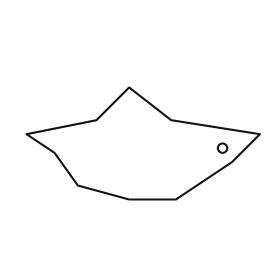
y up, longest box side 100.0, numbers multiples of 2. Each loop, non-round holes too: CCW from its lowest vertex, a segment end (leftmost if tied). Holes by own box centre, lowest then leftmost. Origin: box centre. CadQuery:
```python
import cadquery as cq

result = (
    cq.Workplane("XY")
    .moveTo(-6.0, -24.0)
    .lineTo(14.0, -24.0)
    .lineTo(38.0, -8.0)
    .lineTo(50.0, 4.0)
    .lineTo(12.0, 10.0)
    .lineTo(-6.0, 24.0)
    .lineTo(-20.0, 10.0)
    .lineTo(-50.0, 4.0)
    .lineTo(-38.0, -4.0)
    .lineTo(-28.0, -18.0)
    .close()
    .moveTo(34.0, -2.0)
    .circle(2.0)
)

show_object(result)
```